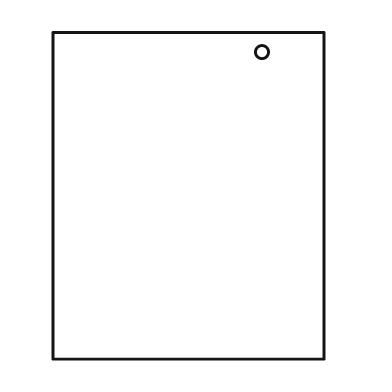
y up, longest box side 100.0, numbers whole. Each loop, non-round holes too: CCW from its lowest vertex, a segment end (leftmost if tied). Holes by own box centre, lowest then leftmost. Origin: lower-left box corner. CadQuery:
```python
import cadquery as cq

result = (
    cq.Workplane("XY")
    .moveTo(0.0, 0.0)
    .lineTo(83.0, 0.0)
    .lineTo(83.0, 100.0)
    .lineTo(0.0, 100.0)
    .close()
    .moveTo(64.0, 94.0)
    .circle(2.0)
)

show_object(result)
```